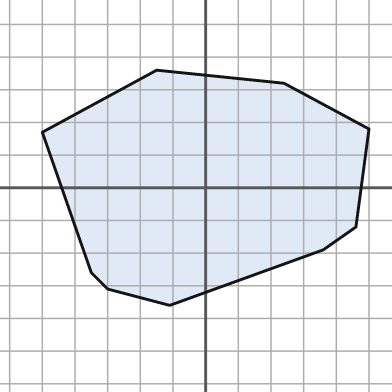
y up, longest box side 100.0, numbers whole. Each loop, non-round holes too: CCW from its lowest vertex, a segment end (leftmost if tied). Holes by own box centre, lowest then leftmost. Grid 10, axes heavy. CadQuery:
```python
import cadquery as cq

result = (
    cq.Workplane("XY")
    .moveTo(-11.0, -36.0)
    .lineTo(36.0, -19.0)
    .lineTo(46.0, -12.0)
    .lineTo(50.0, 18.0)
    .lineTo(24.0, 32.0)
    .lineTo(-15.0, 36.0)
    .lineTo(-50.0, 17.0)
    .lineTo(-35.0, -26.0)
    .lineTo(-30.0, -31.0)
    .close()
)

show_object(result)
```